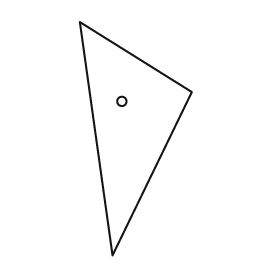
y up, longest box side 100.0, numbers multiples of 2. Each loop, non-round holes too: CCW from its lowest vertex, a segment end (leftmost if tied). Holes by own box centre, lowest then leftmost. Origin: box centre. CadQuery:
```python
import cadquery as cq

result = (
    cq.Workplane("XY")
    .moveTo(-10.0, -50.0)
    .lineTo(24.0, 20.0)
    .lineTo(-24.0, 50.0)
    .close()
    .moveTo(-6.0, 16.0)
    .circle(2.0)
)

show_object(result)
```